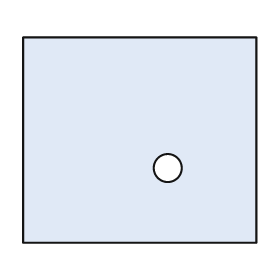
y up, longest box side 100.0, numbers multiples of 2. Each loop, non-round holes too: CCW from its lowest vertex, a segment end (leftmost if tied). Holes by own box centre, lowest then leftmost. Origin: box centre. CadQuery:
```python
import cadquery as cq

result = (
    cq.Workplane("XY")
    .moveTo(-50.0, -44.0)
    .lineTo(50.0, -44.0)
    .lineTo(50.0, 44.0)
    .lineTo(-50.0, 44.0)
    .close()
    .moveTo(12.0, -12.0)
    .circle(6.0)
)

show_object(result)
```